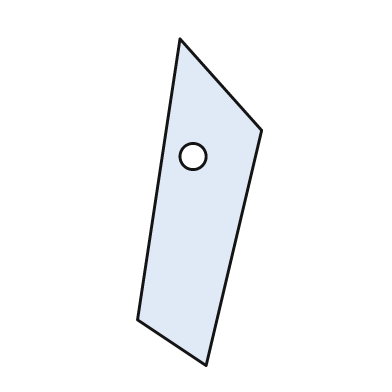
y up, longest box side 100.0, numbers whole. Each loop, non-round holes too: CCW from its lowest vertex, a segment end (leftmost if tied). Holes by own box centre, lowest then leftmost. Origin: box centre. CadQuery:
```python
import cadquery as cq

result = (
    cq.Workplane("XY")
    .moveTo(2.0, -50.0)
    .lineTo(19.0, 22.0)
    .lineTo(-6.0, 50.0)
    .lineTo(-19.0, -36.0)
    .close()
    .moveTo(-2.0, 14.0)
    .circle(4.0)
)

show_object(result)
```